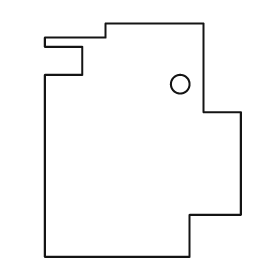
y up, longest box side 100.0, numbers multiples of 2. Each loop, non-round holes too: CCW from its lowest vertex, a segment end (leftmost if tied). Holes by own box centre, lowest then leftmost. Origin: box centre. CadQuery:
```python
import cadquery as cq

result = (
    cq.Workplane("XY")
    .moveTo(-42.0, -50.0)
    .lineTo(20.0, -50.0)
    .lineTo(20.0, -32.0)
    .lineTo(42.0, -32.0)
    .lineTo(42.0, 12.0)
    .lineTo(26.0, 12.0)
    .lineTo(26.0, 50.0)
    .lineTo(-16.0, 50.0)
    .lineTo(-16.0, 44.0)
    .lineTo(-42.0, 44.0)
    .lineTo(-42.0, 40.0)
    .lineTo(-26.0, 40.0)
    .lineTo(-26.0, 28.0)
    .lineTo(-42.0, 28.0)
    .close()
    .moveTo(16.0, 24.0)
    .circle(4.0)
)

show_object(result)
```